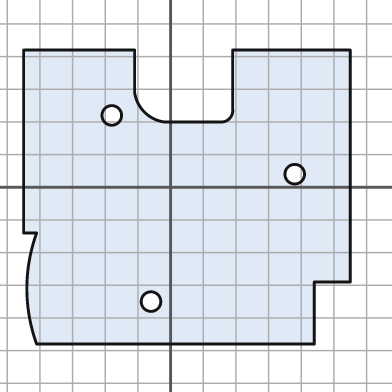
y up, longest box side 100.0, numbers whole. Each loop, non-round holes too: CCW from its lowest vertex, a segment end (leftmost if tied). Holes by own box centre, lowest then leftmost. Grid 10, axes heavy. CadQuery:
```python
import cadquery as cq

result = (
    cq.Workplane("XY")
    .moveTo(-41.0, -48.0)
    .lineTo(44.0, -48.0)
    .lineTo(44.0, -29.0)
    .lineTo(55.0, -29.0)
    .lineTo(55.0, 42.0)
    .lineTo(19.0, 42.0)
    .lineTo(19.0, 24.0)
    .threePointArc((18.0, 21.0), (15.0, 20.0))
    .lineTo(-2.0, 20.0)
    .threePointArc((-8.0, 23.0), (-11.0, 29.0))
    .lineTo(-11.0, 42.0)
    .lineTo(-45.0, 42.0)
    .lineTo(-45.0, -14.0)
    .lineTo(-41.0, -14.0)
    .threePointArc((-44.0, -31.0), (-41.0, -48.0))
    .close()
    .moveTo(-6.0, -35.0)
    .circle(3.0)
    .moveTo(38.0, 4.0)
    .circle(3.0)
    .moveTo(-18.0, 22.0)
    .circle(3.0)
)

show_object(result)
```